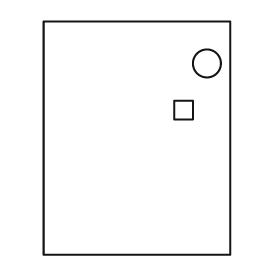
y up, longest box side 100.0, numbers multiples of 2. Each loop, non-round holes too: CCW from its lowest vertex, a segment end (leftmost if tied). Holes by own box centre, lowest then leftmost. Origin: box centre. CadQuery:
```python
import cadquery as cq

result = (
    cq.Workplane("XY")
    .moveTo(-40.0, -50.0)
    .lineTo(40.0, -50.0)
    .lineTo(40.0, 50.0)
    .lineTo(-40.0, 50.0)
    .close()
    .moveTo(16.0, 8.0)
    .lineTo(24.0, 8.0)
    .lineTo(24.0, 16.0)
    .lineTo(16.0, 16.0)
    .close()
    .moveTo(30.0, 32.0)
    .circle(6.0)
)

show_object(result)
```